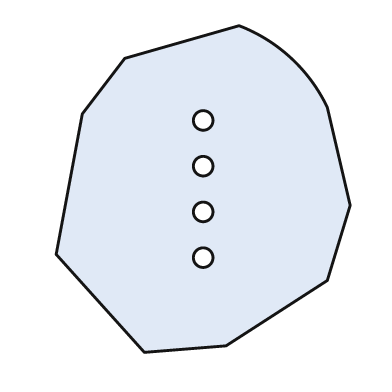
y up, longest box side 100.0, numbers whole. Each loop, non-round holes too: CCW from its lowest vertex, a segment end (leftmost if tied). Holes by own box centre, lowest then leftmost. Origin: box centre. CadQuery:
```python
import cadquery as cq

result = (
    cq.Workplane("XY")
    .moveTo(-18.0, -50.0)
    .lineTo(7.0, -48.0)
    .lineTo(38.0, -28.0)
    .lineTo(45.0, -5.0)
    .lineTo(38.0, 25.0)
    .threePointArc((27.0, 40.0), (11.0, 50.0))
    .lineTo(-24.0, 40.0)
    .lineTo(-37.0, 23.0)
    .lineTo(-45.0, -20.0)
    .close()
    .moveTo(0.0, -21.0)
    .circle(3.0)
    .moveTo(0.0, -7.0)
    .circle(3.0)
    .moveTo(0.0, 7.0)
    .circle(3.0)
    .moveTo(0.0, 21.0)
    .circle(3.0)
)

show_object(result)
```